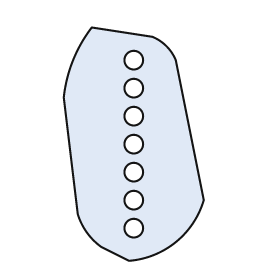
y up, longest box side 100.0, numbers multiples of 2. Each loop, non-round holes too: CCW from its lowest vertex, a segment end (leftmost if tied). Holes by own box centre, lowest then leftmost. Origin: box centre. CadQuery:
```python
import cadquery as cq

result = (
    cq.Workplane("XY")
    .moveTo(-2.0, -50.0)
    .threePointArc((18.0, -42.0), (30.0, -24.0))
    .lineTo(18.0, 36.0)
    .threePointArc((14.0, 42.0), (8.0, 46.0))
    .lineTo(-18.0, 50.0)
    .threePointArc((-26.0, 36.0), (-30.0, 20.0))
    .lineTo(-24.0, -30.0)
    .threePointArc((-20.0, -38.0), (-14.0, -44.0))
    .close()
    .moveTo(0.0, -36.0)
    .circle(4.0)
    .moveTo(0.0, -24.0)
    .circle(4.0)
    .moveTo(0.0, -12.0)
    .circle(4.0)
    .moveTo(0.0, 0.0)
    .circle(4.0)
    .moveTo(0.0, 12.0)
    .circle(4.0)
    .moveTo(0.0, 24.0)
    .circle(4.0)
    .moveTo(0.0, 36.0)
    .circle(4.0)
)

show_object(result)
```